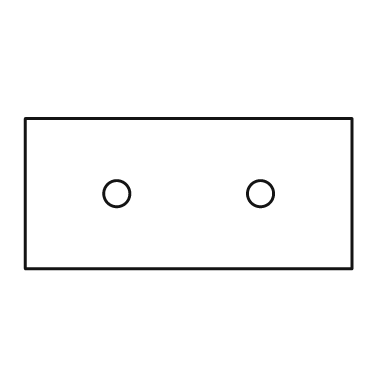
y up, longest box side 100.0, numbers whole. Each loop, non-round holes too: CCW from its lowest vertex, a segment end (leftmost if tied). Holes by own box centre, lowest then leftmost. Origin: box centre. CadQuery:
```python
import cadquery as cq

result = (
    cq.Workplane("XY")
    .moveTo(-50.0, -23.0)
    .lineTo(50.0, -23.0)
    .lineTo(50.0, 23.0)
    .lineTo(-50.0, 23.0)
    .close()
    .moveTo(-22.0, 0.0)
    .circle(4.0)
    .moveTo(22.0, 0.0)
    .circle(4.0)
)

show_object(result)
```